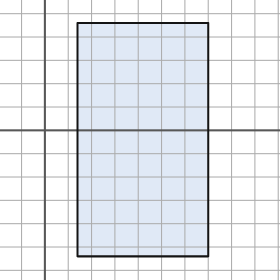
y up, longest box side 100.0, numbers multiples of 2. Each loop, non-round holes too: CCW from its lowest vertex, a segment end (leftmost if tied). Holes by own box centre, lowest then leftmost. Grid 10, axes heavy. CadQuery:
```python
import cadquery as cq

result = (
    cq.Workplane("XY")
    .moveTo(14.0, -54.0)
    .lineTo(70.0, -54.0)
    .lineTo(70.0, 46.0)
    .lineTo(14.0, 46.0)
    .close()
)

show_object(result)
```